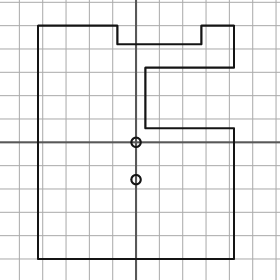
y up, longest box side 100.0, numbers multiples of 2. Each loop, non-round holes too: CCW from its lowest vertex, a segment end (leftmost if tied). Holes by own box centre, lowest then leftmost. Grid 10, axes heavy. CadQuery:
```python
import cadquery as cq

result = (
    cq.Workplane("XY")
    .moveTo(-42.0, -50.0)
    .lineTo(42.0, -50.0)
    .lineTo(42.0, 6.0)
    .lineTo(4.0, 6.0)
    .lineTo(4.0, 32.0)
    .lineTo(42.0, 32.0)
    .lineTo(42.0, 50.0)
    .lineTo(28.0, 50.0)
    .lineTo(28.0, 42.0)
    .lineTo(-8.0, 42.0)
    .lineTo(-8.0, 50.0)
    .lineTo(-42.0, 50.0)
    .close()
    .moveTo(0.0, -16.0)
    .circle(2.0)
    .moveTo(0.0, 0.0)
    .circle(2.0)
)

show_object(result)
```